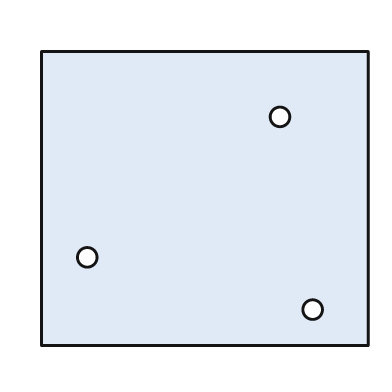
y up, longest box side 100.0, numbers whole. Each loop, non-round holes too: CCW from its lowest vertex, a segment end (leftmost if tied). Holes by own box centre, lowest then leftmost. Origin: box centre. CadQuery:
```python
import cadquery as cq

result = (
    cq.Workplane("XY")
    .moveTo(-50.0, -45.0)
    .lineTo(50.0, -45.0)
    .lineTo(50.0, 45.0)
    .lineTo(-50.0, 45.0)
    .close()
    .moveTo(33.0, -34.0)
    .circle(3.0)
    .moveTo(-36.0, -18.0)
    .circle(3.0)
    .moveTo(23.0, 25.0)
    .circle(3.0)
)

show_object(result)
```